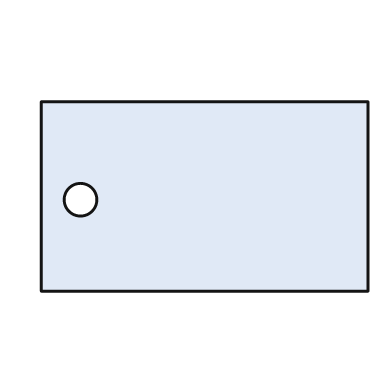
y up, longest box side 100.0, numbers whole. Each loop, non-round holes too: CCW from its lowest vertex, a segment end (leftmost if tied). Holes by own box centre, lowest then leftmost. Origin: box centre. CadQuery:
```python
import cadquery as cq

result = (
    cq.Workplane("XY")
    .moveTo(-50.0, -29.0)
    .lineTo(50.0, -29.0)
    .lineTo(50.0, 29.0)
    .lineTo(-50.0, 29.0)
    .close()
    .moveTo(-38.0, -1.0)
    .circle(5.0)
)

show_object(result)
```